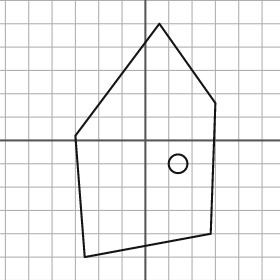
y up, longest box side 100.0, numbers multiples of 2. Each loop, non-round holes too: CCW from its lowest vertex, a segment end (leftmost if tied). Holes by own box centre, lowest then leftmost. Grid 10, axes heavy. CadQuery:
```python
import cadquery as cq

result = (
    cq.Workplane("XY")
    .moveTo(-26.0, -50.0)
    .lineTo(28.0, -40.0)
    .lineTo(30.0, 16.0)
    .lineTo(6.0, 50.0)
    .lineTo(-30.0, 2.0)
    .close()
    .moveTo(14.0, -10.0)
    .circle(4.0)
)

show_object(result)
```